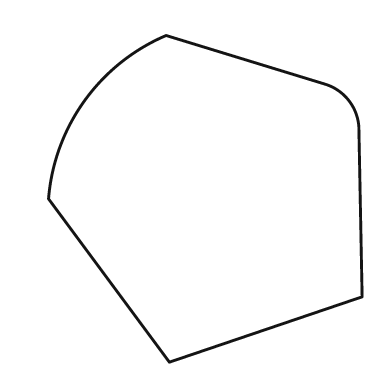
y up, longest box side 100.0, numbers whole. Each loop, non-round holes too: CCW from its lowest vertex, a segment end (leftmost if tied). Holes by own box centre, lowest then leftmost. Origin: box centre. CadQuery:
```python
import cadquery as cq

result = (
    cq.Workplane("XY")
    .moveTo(-11.0, -50.0)
    .lineTo(48.0, -30.0)
    .lineTo(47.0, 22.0)
    .threePointArc((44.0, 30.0), (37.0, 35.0))
    .lineTo(-12.0, 50.0)
    .threePointArc((-37.0, 30.0), (-48.0, 0.0))
    .close()
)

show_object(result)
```